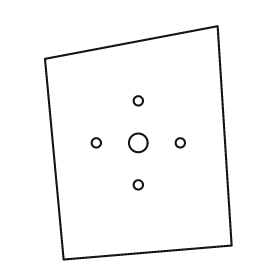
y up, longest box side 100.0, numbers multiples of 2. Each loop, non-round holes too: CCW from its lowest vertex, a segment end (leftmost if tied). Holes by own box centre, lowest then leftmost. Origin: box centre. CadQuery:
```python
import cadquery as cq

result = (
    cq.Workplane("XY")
    .moveTo(-32.0, -50.0)
    .lineTo(40.0, -44.0)
    .lineTo(34.0, 50.0)
    .lineTo(-40.0, 36.0)
    .close()
    .moveTo(0.0, -18.0)
    .circle(2.0)
    .moveTo(-18.0, 0.0)
    .circle(2.0)
    .moveTo(0.0, 0.0)
    .circle(4.0)
    .moveTo(18.0, 0.0)
    .circle(2.0)
    .moveTo(0.0, 18.0)
    .circle(2.0)
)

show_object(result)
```